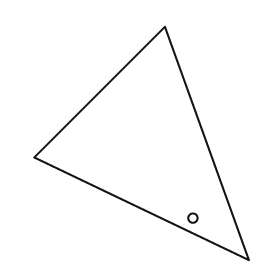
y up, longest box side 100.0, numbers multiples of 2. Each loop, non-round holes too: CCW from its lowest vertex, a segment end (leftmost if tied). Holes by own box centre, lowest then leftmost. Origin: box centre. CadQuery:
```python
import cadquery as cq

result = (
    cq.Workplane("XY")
    .moveTo(46.0, -50.0)
    .lineTo(10.0, 50.0)
    .lineTo(-46.0, -6.0)
    .close()
    .moveTo(22.0, -32.0)
    .circle(2.0)
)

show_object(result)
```